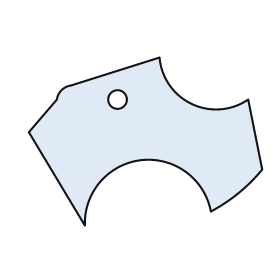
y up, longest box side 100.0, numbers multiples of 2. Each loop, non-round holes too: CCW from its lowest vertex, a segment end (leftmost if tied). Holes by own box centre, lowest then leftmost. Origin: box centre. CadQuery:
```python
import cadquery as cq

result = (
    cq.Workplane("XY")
    .moveTo(-26.0, -36.0)
    .threePointArc((-2.0, -8.0), (28.0, -30.0))
    .threePointArc((40.0, -22.0), (50.0, -12.0))
    .lineTo(44.0, 18.0)
    .threePointArc((20.0, 16.0), (6.0, 36.0))
    .lineTo(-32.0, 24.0)
    .threePointArc((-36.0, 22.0), (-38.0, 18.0))
    .lineTo(-50.0, 4.0)
    .close()
    .moveTo(-12.0, 18.0)
    .circle(4.0)
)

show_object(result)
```